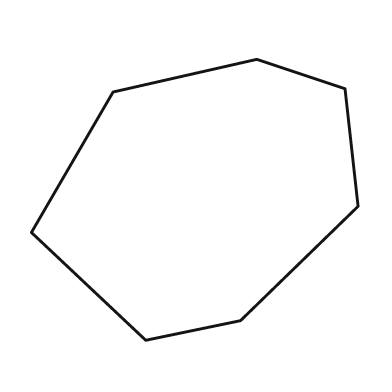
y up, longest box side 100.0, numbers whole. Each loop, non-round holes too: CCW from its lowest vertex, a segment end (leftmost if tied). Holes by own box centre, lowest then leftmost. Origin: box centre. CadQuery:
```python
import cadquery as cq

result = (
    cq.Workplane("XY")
    .moveTo(-15.0, -43.0)
    .lineTo(14.0, -37.0)
    .lineTo(50.0, -2.0)
    .lineTo(46.0, 34.0)
    .lineTo(19.0, 43.0)
    .lineTo(-25.0, 33.0)
    .lineTo(-50.0, -10.0)
    .close()
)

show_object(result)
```